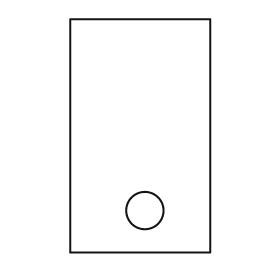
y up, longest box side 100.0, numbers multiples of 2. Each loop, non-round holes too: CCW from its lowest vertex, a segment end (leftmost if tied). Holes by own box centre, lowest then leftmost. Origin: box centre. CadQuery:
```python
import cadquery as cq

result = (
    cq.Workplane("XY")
    .moveTo(-30.0, -50.0)
    .lineTo(30.0, -50.0)
    .lineTo(30.0, 50.0)
    .lineTo(-30.0, 50.0)
    .close()
    .moveTo(2.0, -32.0)
    .circle(8.0)
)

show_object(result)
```